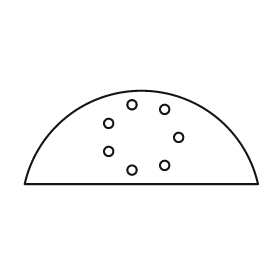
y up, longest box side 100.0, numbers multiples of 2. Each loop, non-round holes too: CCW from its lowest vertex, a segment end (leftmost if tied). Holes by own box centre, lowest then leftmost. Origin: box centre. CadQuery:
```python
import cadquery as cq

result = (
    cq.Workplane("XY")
    .moveTo(-50.0, -20.0)
    .lineTo(50.0, -20.0)
    .threePointArc((0.0, 20.0), (-50.0, -20.0))
    .close()
    .moveTo(-4.0, -14.0)
    .circle(2.0)
    .moveTo(10.0, -12.0)
    .circle(2.0)
    .moveTo(-14.0, -6.0)
    .circle(2.0)
    .moveTo(16.0, 0.0)
    .circle(2.0)
    .moveTo(-14.0, 6.0)
    .circle(2.0)
    .moveTo(10.0, 12.0)
    .circle(2.0)
    .moveTo(-4.0, 14.0)
    .circle(2.0)
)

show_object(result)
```